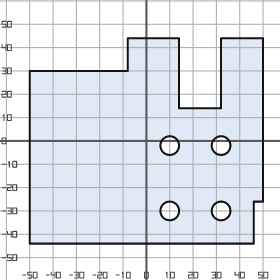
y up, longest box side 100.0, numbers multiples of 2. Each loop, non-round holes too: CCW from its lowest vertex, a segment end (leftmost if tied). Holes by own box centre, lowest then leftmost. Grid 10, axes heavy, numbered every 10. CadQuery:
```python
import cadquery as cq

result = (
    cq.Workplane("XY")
    .moveTo(-50.0, -44.0)
    .lineTo(46.0, -44.0)
    .lineTo(46.0, -26.0)
    .lineTo(50.0, -26.0)
    .lineTo(50.0, 44.0)
    .lineTo(32.0, 44.0)
    .lineTo(32.0, 14.0)
    .lineTo(14.0, 14.0)
    .lineTo(14.0, 44.0)
    .lineTo(-8.0, 44.0)
    .lineTo(-8.0, 30.0)
    .lineTo(-50.0, 30.0)
    .close()
    .moveTo(10.0, -30.0)
    .circle(4.0)
    .moveTo(32.0, -30.0)
    .circle(4.0)
    .moveTo(10.0, -2.0)
    .circle(4.0)
    .moveTo(32.0, -2.0)
    .circle(4.0)
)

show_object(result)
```